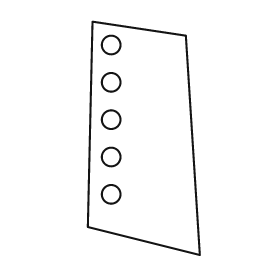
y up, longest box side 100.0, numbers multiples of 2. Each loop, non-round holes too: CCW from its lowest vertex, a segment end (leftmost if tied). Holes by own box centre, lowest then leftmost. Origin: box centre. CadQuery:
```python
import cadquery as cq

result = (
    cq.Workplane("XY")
    .moveTo(24.0, -50.0)
    .lineTo(18.0, 44.0)
    .lineTo(-22.0, 50.0)
    .lineTo(-24.0, -38.0)
    .close()
    .moveTo(-14.0, -24.0)
    .circle(4.0)
    .moveTo(-14.0, -8.0)
    .circle(4.0)
    .moveTo(-14.0, 8.0)
    .circle(4.0)
    .moveTo(-14.0, 24.0)
    .circle(4.0)
    .moveTo(-14.0, 40.0)
    .circle(4.0)
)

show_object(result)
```